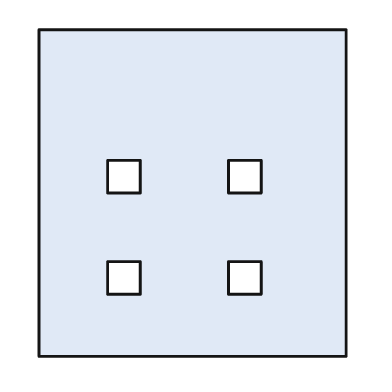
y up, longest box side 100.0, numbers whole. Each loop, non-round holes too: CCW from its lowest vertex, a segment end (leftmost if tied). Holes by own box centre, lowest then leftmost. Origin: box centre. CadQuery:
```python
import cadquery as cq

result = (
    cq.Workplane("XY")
    .moveTo(-47.0, -50.0)
    .lineTo(47.0, -50.0)
    .lineTo(47.0, 50.0)
    .lineTo(-47.0, 50.0)
    .close()
    .moveTo(-26.0, -31.0)
    .lineTo(-16.0, -31.0)
    .lineTo(-16.0, -21.0)
    .lineTo(-26.0, -21.0)
    .close()
    .moveTo(11.0, -31.0)
    .lineTo(21.0, -31.0)
    .lineTo(21.0, -21.0)
    .lineTo(11.0, -21.0)
    .close()
    .moveTo(-26.0, 0.0)
    .lineTo(-16.0, 0.0)
    .lineTo(-16.0, 10.0)
    .lineTo(-26.0, 10.0)
    .close()
    .moveTo(11.0, 0.0)
    .lineTo(21.0, 0.0)
    .lineTo(21.0, 10.0)
    .lineTo(11.0, 10.0)
    .close()
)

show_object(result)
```